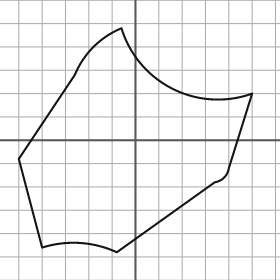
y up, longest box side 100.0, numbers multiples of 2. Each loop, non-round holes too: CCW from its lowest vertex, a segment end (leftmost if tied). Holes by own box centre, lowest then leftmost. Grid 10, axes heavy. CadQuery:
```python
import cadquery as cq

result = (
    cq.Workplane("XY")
    .moveTo(-8.0, -48.0)
    .lineTo(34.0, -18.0)
    .threePointArc((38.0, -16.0), (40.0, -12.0))
    .lineTo(50.0, 20.0)
    .threePointArc((16.0, 22.0), (-6.0, 48.0))
    .threePointArc((-18.0, 40.0), (-26.0, 28.0))
    .lineTo(-50.0, -8.0)
    .lineTo(-40.0, -46.0)
    .threePointArc((-24.0, -44.0), (-8.0, -48.0))
    .close()
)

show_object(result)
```